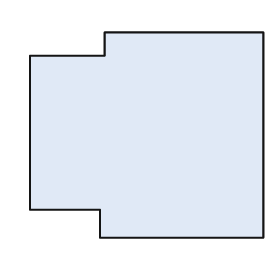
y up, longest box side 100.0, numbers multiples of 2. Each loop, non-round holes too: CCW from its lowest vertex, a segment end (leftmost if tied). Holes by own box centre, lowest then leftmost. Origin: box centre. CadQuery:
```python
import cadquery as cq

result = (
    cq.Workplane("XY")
    .moveTo(-20.0, -44.0)
    .lineTo(50.0, -44.0)
    .lineTo(50.0, 44.0)
    .lineTo(-18.0, 44.0)
    .lineTo(-18.0, 34.0)
    .lineTo(-50.0, 34.0)
    .lineTo(-50.0, -32.0)
    .lineTo(-20.0, -32.0)
    .close()
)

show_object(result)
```